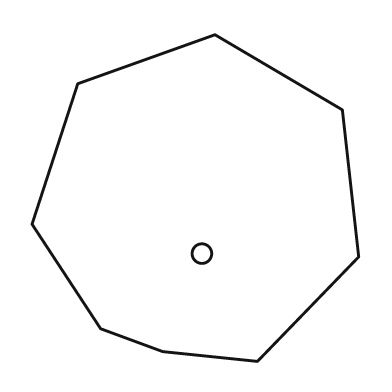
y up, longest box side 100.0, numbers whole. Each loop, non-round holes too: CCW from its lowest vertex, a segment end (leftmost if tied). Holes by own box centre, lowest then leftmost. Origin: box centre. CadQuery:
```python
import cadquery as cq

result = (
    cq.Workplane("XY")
    .moveTo(19.0, -50.0)
    .lineTo(50.0, -18.0)
    .lineTo(45.0, 27.0)
    .lineTo(6.0, 50.0)
    .lineTo(-36.0, 35.0)
    .lineTo(-50.0, -8.0)
    .lineTo(-29.0, -40.0)
    .lineTo(-10.0, -47.0)
    .close()
    .moveTo(2.0, -17.0)
    .circle(3.0)
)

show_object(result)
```